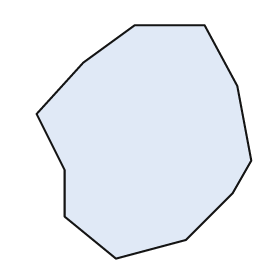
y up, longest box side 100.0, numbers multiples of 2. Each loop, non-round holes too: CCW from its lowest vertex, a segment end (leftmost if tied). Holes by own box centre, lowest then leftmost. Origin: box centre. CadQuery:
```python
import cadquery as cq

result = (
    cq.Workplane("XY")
    .moveTo(-12.0, -50.0)
    .lineTo(18.0, -42.0)
    .lineTo(38.0, -22.0)
    .lineTo(46.0, -8.0)
    .lineTo(40.0, 24.0)
    .lineTo(26.0, 50.0)
    .lineTo(-4.0, 50.0)
    .lineTo(-26.0, 34.0)
    .lineTo(-46.0, 12.0)
    .lineTo(-34.0, -12.0)
    .lineTo(-34.0, -32.0)
    .close()
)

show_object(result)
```